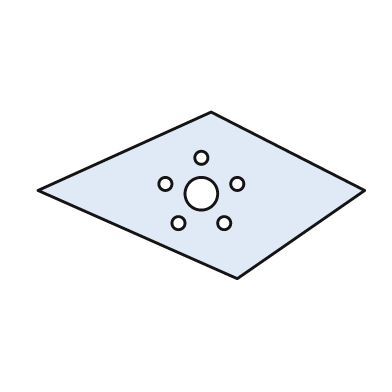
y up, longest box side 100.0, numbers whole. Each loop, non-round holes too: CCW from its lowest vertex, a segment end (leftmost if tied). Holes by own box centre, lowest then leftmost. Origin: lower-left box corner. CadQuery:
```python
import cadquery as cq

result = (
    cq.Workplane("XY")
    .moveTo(61.0, 0.0)
    .lineTo(100.0, 27.0)
    .lineTo(53.0, 51.0)
    .lineTo(0.0, 27.0)
    .close()
    .moveTo(43.0, 17.0)
    .circle(2.0)
    .moveTo(57.0, 17.0)
    .circle(2.0)
    .moveTo(50.0, 26.0)
    .circle(5.0)
    .moveTo(39.0, 29.0)
    .circle(2.0)
    .moveTo(61.0, 29.0)
    .circle(2.0)
    .moveTo(50.0, 37.0)
    .circle(2.0)
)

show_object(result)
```